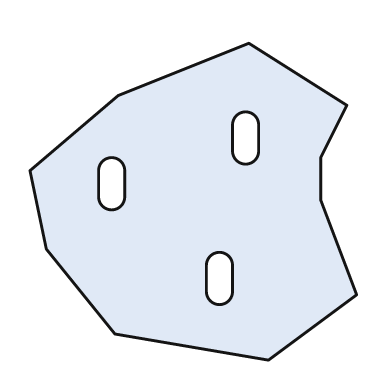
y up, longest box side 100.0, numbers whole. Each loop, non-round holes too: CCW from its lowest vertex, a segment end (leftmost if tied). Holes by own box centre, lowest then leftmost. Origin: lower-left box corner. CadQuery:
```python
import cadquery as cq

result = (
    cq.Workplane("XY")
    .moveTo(73.0, 0.0)
    .lineTo(100.0, 20.0)
    .lineTo(89.0, 49.0)
    .lineTo(89.0, 62.0)
    .lineTo(97.0, 78.0)
    .lineTo(67.0, 97.0)
    .lineTo(27.0, 81.0)
    .lineTo(0.0, 58.0)
    .lineTo(5.0, 34.0)
    .lineTo(26.0, 8.0)
    .close()
    .moveTo(54.0, 21.0)
    .threePointArc((58.0, 17.0), (62.0, 21.0))
    .lineTo(62.0, 29.0)
    .threePointArc((58.0, 33.0), (54.0, 29.0))
    .close()
    .moveTo(21.0, 50.0)
    .threePointArc((25.0, 46.0), (29.0, 50.0))
    .lineTo(29.0, 58.0)
    .threePointArc((25.0, 62.0), (21.0, 58.0))
    .close()
    .moveTo(62.0, 64.0)
    .threePointArc((66.0, 60.0), (70.0, 64.0))
    .lineTo(70.0, 72.0)
    .threePointArc((66.0, 76.0), (62.0, 72.0))
    .close()
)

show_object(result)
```